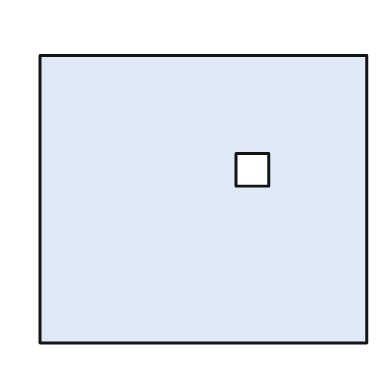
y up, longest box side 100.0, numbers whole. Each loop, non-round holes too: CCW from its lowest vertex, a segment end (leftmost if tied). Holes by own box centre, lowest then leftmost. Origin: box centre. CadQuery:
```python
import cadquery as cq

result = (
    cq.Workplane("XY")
    .moveTo(-50.0, -44.0)
    .lineTo(50.0, -44.0)
    .lineTo(50.0, 44.0)
    .lineTo(-50.0, 44.0)
    .close()
    .moveTo(10.0, 4.0)
    .lineTo(20.0, 4.0)
    .lineTo(20.0, 14.0)
    .lineTo(10.0, 14.0)
    .close()
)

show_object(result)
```